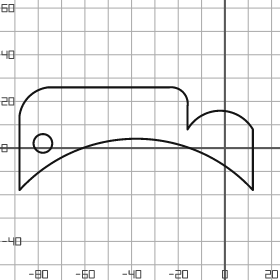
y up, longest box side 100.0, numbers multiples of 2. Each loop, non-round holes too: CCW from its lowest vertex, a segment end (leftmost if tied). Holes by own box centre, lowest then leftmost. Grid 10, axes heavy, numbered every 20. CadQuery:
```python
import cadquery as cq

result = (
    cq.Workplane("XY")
    .moveTo(-88.0, -18.0)
    .threePointArc((-38.0, 4.0), (12.0, -18.0))
    .lineTo(12.0, 8.0)
    .threePointArc((-2.0, 16.0), (-16.0, 8.0))
    .lineTo(-16.0, 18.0)
    .threePointArc((-18.0, 24.0), (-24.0, 26.0))
    .lineTo(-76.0, 26.0)
    .threePointArc((-84.0, 22.0), (-88.0, 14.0))
    .close()
    .moveTo(-78.0, 2.0)
    .circle(4.0)
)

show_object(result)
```